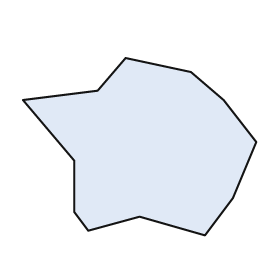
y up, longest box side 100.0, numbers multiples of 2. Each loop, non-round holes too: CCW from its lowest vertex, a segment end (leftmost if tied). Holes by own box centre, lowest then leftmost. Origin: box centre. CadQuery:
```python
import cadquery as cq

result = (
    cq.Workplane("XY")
    .moveTo(28.0, -38.0)
    .lineTo(40.0, -22.0)
    .lineTo(50.0, 2.0)
    .lineTo(36.0, 20.0)
    .lineTo(22.0, 32.0)
    .lineTo(-6.0, 38.0)
    .lineTo(-18.0, 24.0)
    .lineTo(-50.0, 20.0)
    .lineTo(-28.0, -6.0)
    .lineTo(-28.0, -28.0)
    .lineTo(-22.0, -36.0)
    .lineTo(0.0, -30.0)
    .close()
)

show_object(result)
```